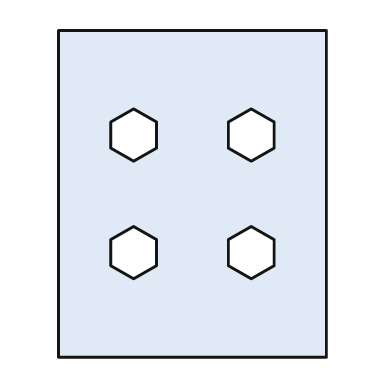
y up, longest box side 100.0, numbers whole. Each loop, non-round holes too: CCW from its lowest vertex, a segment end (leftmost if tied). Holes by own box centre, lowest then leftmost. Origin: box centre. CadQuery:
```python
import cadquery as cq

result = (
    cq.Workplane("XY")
    .moveTo(-41.0, -50.0)
    .lineTo(41.0, -50.0)
    .lineTo(41.0, 50.0)
    .lineTo(-41.0, 50.0)
    .close()
    .moveTo(-18.0, -26.0)
    .lineTo(-11.0, -22.0)
    .lineTo(-11.0, -14.0)
    .lineTo(-18.0, -10.0)
    .lineTo(-25.0, -14.0)
    .lineTo(-25.0, -22.0)
    .close()
    .moveTo(18.0, -26.0)
    .lineTo(25.0, -22.0)
    .lineTo(25.0, -14.0)
    .lineTo(18.0, -10.0)
    .lineTo(11.0, -14.0)
    .lineTo(11.0, -22.0)
    .close()
    .moveTo(-18.0, 10.0)
    .lineTo(-11.0, 14.0)
    .lineTo(-11.0, 22.0)
    .lineTo(-18.0, 26.0)
    .lineTo(-25.0, 22.0)
    .lineTo(-25.0, 14.0)
    .close()
    .moveTo(18.0, 10.0)
    .lineTo(25.0, 14.0)
    .lineTo(25.0, 22.0)
    .lineTo(18.0, 26.0)
    .lineTo(11.0, 22.0)
    .lineTo(11.0, 14.0)
    .close()
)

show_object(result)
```